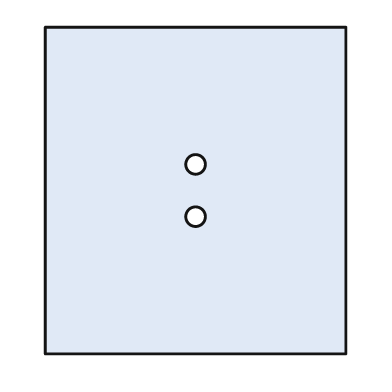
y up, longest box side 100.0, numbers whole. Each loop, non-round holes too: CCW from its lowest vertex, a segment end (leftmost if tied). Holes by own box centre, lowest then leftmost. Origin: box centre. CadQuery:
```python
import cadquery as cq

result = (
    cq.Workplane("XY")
    .moveTo(-46.0, -50.0)
    .lineTo(46.0, -50.0)
    .lineTo(46.0, 50.0)
    .lineTo(-46.0, 50.0)
    .close()
    .moveTo(0.0, -8.0)
    .circle(3.0)
    .moveTo(0.0, 8.0)
    .circle(3.0)
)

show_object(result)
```